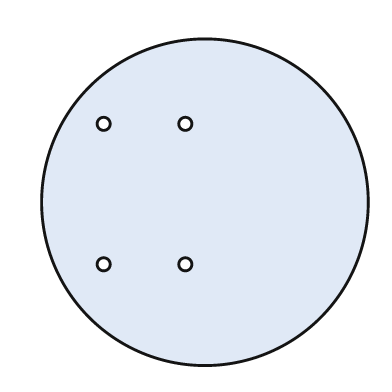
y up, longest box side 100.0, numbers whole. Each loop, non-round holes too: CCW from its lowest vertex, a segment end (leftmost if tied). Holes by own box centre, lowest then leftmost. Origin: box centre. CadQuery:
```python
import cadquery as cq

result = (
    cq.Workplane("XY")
    .moveTo(0.0, 0.0)
    .circle(50.0)
    .moveTo(-31.0, -19.0)
    .circle(2.0)
    .moveTo(-6.0, -19.0)
    .circle(2.0)
    .moveTo(-31.0, 24.0)
    .circle(2.0)
    .moveTo(-6.0, 24.0)
    .circle(2.0)
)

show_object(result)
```